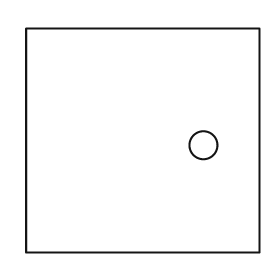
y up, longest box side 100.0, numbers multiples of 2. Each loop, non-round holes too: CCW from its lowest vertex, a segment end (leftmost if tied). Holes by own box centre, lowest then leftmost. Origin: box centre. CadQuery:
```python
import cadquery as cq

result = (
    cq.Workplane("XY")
    .moveTo(-50.0, -48.0)
    .lineTo(50.0, -48.0)
    .lineTo(50.0, 48.0)
    .lineTo(-50.0, 48.0)
    .close()
    .moveTo(26.0, -2.0)
    .circle(6.0)
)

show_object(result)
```